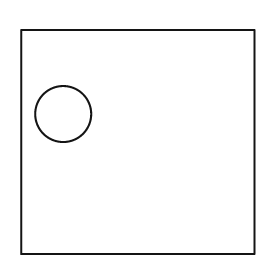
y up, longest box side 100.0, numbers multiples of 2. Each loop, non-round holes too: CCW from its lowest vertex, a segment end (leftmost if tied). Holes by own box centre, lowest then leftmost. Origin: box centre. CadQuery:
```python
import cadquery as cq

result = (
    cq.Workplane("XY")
    .moveTo(-50.0, -48.0)
    .lineTo(50.0, -48.0)
    .lineTo(50.0, 48.0)
    .lineTo(-50.0, 48.0)
    .close()
    .moveTo(-32.0, 12.0)
    .circle(12.0)
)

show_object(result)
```